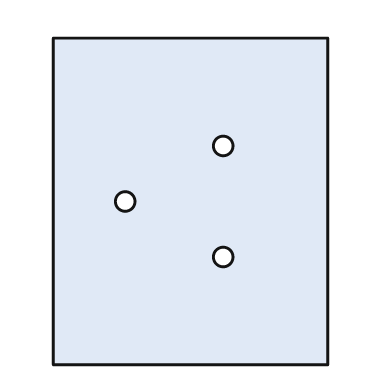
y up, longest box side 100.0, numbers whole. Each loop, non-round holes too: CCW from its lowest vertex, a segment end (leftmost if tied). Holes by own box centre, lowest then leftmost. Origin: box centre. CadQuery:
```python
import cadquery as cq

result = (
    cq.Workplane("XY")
    .moveTo(-42.0, -50.0)
    .lineTo(42.0, -50.0)
    .lineTo(42.0, 50.0)
    .lineTo(-42.0, 50.0)
    .close()
    .moveTo(10.0, -17.0)
    .circle(3.0)
    .moveTo(-20.0, 0.0)
    .circle(3.0)
    .moveTo(10.0, 17.0)
    .circle(3.0)
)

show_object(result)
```